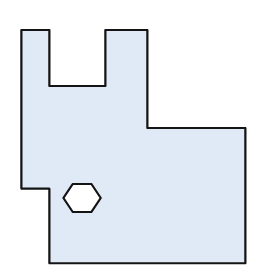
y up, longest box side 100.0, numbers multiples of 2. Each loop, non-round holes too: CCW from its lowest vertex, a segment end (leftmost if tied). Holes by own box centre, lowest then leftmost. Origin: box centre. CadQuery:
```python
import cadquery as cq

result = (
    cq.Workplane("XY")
    .moveTo(-36.0, -50.0)
    .lineTo(48.0, -50.0)
    .lineTo(48.0, 8.0)
    .lineTo(6.0, 8.0)
    .lineTo(6.0, 50.0)
    .lineTo(-12.0, 50.0)
    .lineTo(-12.0, 26.0)
    .lineTo(-36.0, 26.0)
    .lineTo(-36.0, 50.0)
    .lineTo(-48.0, 50.0)
    .lineTo(-48.0, -18.0)
    .lineTo(-36.0, -18.0)
    .close()
    .moveTo(-26.0, -28.0)
    .lineTo(-18.0, -28.0)
    .lineTo(-14.0, -22.0)
    .lineTo(-18.0, -16.0)
    .lineTo(-26.0, -16.0)
    .lineTo(-30.0, -22.0)
    .close()
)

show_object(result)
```